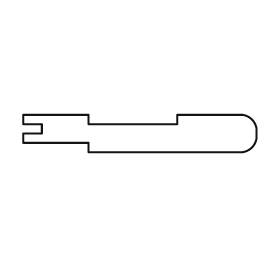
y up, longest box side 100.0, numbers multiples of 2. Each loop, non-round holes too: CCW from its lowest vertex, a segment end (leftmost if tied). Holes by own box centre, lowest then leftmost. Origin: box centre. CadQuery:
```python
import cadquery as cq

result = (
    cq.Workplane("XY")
    .moveTo(-22.0, -8.0)
    .lineTo(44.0, -8.0)
    .threePointArc((48.0, -6.0), (50.0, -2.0))
    .lineTo(50.0, 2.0)
    .threePointArc((48.0, 6.0), (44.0, 8.0))
    .lineTo(16.0, 8.0)
    .lineTo(16.0, 4.0)
    .lineTo(-22.0, 4.0)
    .lineTo(-22.0, 8.0)
    .lineTo(-50.0, 8.0)
    .lineTo(-50.0, 4.0)
    .lineTo(-42.0, 4.0)
    .lineTo(-42.0, 0.0)
    .lineTo(-50.0, 0.0)
    .lineTo(-50.0, -4.0)
    .lineTo(-22.0, -4.0)
    .close()
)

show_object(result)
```